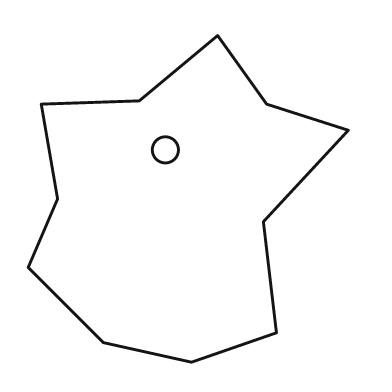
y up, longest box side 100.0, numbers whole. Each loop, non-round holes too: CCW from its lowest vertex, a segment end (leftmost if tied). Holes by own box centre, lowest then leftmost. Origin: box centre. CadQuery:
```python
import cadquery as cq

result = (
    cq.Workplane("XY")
    .moveTo(1.0, -50.0)
    .lineTo(27.0, -41.0)
    .lineTo(23.0, -7.0)
    .lineTo(49.0, 21.0)
    .lineTo(24.0, 29.0)
    .lineTo(9.0, 50.0)
    .lineTo(-15.0, 30.0)
    .lineTo(-45.0, 29.0)
    .lineTo(-40.0, 0.0)
    .lineTo(-49.0, -21.0)
    .lineTo(-26.0, -44.0)
    .close()
    .moveTo(-7.0, 15.0)
    .circle(4.0)
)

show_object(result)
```